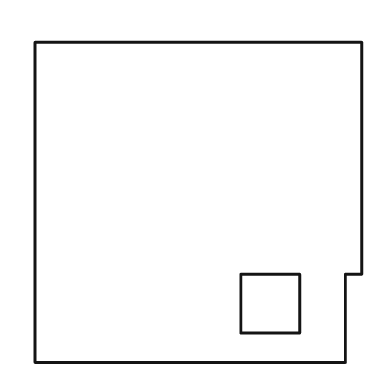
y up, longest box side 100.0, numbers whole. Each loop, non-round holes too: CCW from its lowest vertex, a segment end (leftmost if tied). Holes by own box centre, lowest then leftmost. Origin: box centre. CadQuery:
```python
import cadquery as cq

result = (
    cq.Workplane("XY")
    .moveTo(-50.0, -49.0)
    .lineTo(45.0, -49.0)
    .lineTo(45.0, -22.0)
    .lineTo(50.0, -22.0)
    .lineTo(50.0, 49.0)
    .lineTo(-50.0, 49.0)
    .close()
    .moveTo(13.0, -40.0)
    .lineTo(31.0, -40.0)
    .lineTo(31.0, -22.0)
    .lineTo(13.0, -22.0)
    .close()
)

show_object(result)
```